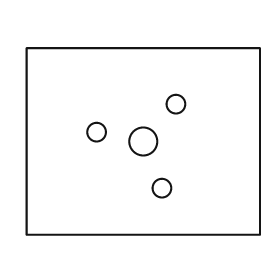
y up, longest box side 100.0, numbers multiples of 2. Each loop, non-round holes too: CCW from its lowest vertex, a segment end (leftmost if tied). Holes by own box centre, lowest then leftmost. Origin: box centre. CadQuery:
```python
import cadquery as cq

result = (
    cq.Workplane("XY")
    .moveTo(-50.0, -40.0)
    .lineTo(50.0, -40.0)
    .lineTo(50.0, 40.0)
    .lineTo(-50.0, 40.0)
    .close()
    .moveTo(8.0, -20.0)
    .circle(4.0)
    .moveTo(0.0, 0.0)
    .circle(6.0)
    .moveTo(-20.0, 4.0)
    .circle(4.0)
    .moveTo(14.0, 16.0)
    .circle(4.0)
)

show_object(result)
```